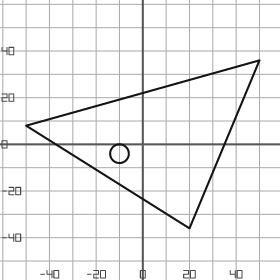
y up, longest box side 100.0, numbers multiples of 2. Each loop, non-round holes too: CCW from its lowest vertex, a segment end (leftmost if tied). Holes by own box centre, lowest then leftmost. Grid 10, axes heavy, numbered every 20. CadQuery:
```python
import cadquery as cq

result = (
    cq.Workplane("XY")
    .moveTo(20.0, -36.0)
    .lineTo(50.0, 36.0)
    .lineTo(-50.0, 8.0)
    .close()
    .moveTo(-10.0, -4.0)
    .circle(4.0)
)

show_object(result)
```